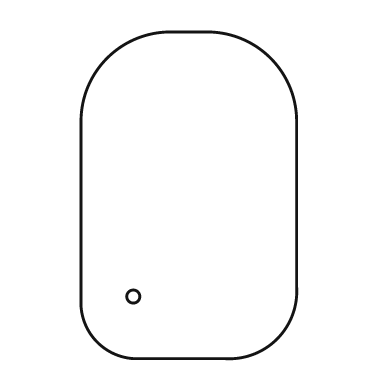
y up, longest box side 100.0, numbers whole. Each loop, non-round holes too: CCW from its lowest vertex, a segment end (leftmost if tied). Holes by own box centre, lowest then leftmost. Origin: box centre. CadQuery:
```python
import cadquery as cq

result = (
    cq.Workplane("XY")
    .moveTo(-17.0, -50.0)
    .lineTo(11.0, -50.0)
    .threePointArc((27.0, -44.0), (33.0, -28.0))
    .lineTo(33.0, 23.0)
    .threePointArc((25.0, 42.0), (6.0, 50.0))
    .lineTo(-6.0, 50.0)
    .threePointArc((-25.0, 42.0), (-33.0, 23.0))
    .lineTo(-33.0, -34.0)
    .threePointArc((-28.0, -45.0), (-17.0, -50.0))
    .close()
    .moveTo(-17.0, -31.0)
    .circle(2.0)
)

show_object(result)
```